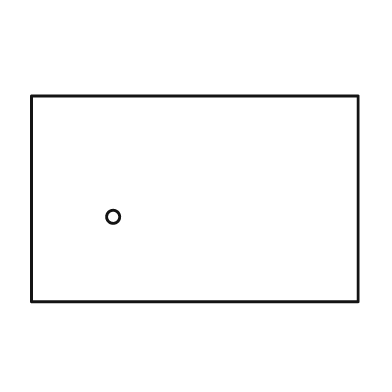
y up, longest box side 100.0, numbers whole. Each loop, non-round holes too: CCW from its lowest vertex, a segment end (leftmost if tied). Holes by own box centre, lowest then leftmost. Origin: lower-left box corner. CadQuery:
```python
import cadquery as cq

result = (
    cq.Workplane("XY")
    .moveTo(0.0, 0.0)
    .lineTo(100.0, 0.0)
    .lineTo(100.0, 63.0)
    .lineTo(0.0, 63.0)
    .close()
    .moveTo(25.0, 26.0)
    .circle(2.0)
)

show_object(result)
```